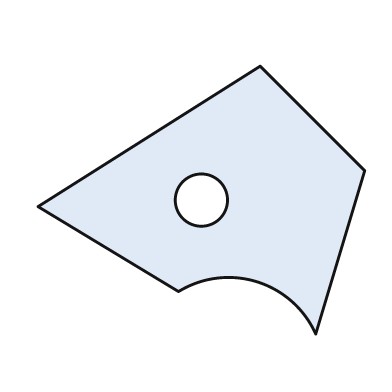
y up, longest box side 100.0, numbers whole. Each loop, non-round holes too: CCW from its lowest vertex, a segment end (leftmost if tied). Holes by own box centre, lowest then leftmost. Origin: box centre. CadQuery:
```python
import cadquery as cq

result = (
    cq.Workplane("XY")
    .moveTo(35.0, -41.0)
    .lineTo(50.0, 9.0)
    .lineTo(18.0, 41.0)
    .lineTo(-50.0, -2.0)
    .lineTo(-7.0, -28.0)
    .threePointArc((17.0, -25.0), (35.0, -41.0))
    .close()
    .moveTo(0.0, 0.0)
    .circle(8.0)
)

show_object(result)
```